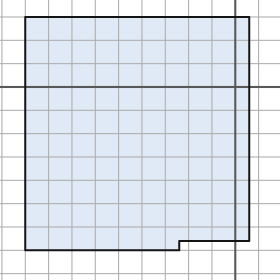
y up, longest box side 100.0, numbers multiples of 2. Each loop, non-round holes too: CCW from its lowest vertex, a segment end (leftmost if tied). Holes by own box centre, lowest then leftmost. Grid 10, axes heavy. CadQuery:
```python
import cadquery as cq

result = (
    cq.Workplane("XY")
    .moveTo(-90.0, -70.0)
    .lineTo(-24.0, -70.0)
    .lineTo(-24.0, -66.0)
    .lineTo(6.0, -66.0)
    .lineTo(6.0, 30.0)
    .lineTo(-90.0, 30.0)
    .close()
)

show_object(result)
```